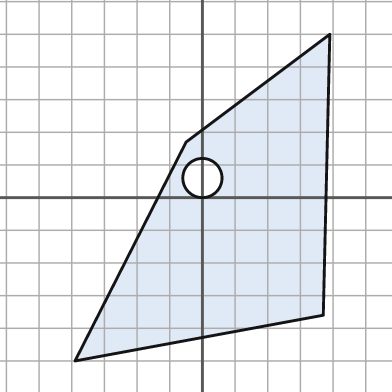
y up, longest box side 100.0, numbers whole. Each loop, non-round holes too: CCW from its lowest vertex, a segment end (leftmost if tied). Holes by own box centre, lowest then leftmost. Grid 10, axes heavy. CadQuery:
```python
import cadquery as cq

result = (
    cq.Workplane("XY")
    .moveTo(-39.0, -50.0)
    .lineTo(37.0, -36.0)
    .lineTo(39.0, 50.0)
    .lineTo(-5.0, 17.0)
    .close()
    .moveTo(0.0, 6.0)
    .circle(6.0)
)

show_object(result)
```